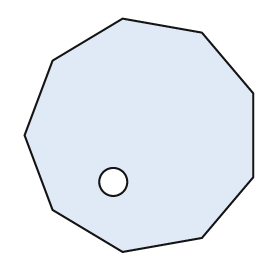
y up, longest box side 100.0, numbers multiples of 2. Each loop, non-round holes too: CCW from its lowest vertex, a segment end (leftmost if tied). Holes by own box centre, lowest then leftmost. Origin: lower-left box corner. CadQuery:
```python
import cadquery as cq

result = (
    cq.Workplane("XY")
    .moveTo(42.0, 0.0)
    .lineTo(76.0, 6.0)
    .lineTo(98.0, 32.0)
    .lineTo(98.0, 68.0)
    .lineTo(76.0, 94.0)
    .lineTo(42.0, 100.0)
    .lineTo(12.0, 82.0)
    .lineTo(0.0, 50.0)
    .lineTo(12.0, 18.0)
    .close()
    .moveTo(38.0, 30.0)
    .circle(6.0)
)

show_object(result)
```